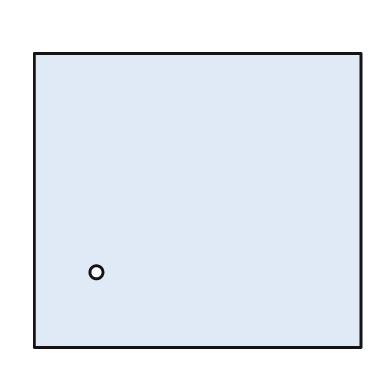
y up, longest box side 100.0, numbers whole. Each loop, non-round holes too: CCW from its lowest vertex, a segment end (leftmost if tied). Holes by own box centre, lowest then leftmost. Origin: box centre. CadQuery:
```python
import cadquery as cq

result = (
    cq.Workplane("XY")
    .moveTo(-50.0, -45.0)
    .lineTo(50.0, -45.0)
    .lineTo(50.0, 45.0)
    .lineTo(-50.0, 45.0)
    .close()
    .moveTo(-31.0, -22.0)
    .circle(2.0)
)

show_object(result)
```